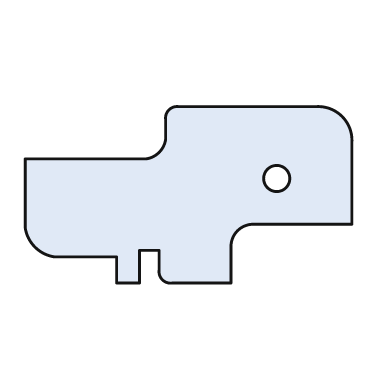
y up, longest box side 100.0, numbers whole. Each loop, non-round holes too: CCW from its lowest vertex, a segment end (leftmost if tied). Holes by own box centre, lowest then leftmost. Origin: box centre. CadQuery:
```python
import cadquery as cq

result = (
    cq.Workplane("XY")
    .moveTo(-22.0, -27.0)
    .lineTo(-15.0, -27.0)
    .lineTo(-15.0, -17.0)
    .lineTo(-9.0, -17.0)
    .lineTo(-9.0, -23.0)
    .threePointArc((-8.0, -26.0), (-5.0, -27.0))
    .lineTo(13.0, -27.0)
    .lineTo(13.0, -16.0)
    .threePointArc((15.0, -11.0), (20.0, -9.0))
    .lineTo(50.0, -9.0)
    .lineTo(50.0, 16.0)
    .threePointArc((47.0, 24.0), (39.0, 27.0))
    .lineTo(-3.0, 27.0)
    .threePointArc((-6.0, 26.0), (-7.0, 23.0))
    .lineTo(-7.0, 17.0)
    .threePointArc((-9.0, 13.0), (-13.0, 11.0))
    .lineTo(-50.0, 11.0)
    .lineTo(-50.0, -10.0)
    .threePointArc((-47.0, -16.0), (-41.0, -19.0))
    .lineTo(-22.0, -19.0)
    .close()
    .moveTo(27.0, 5.0)
    .circle(4.0)
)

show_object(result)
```